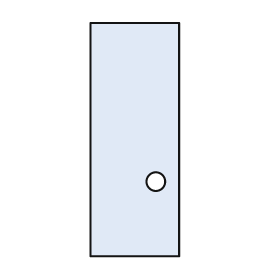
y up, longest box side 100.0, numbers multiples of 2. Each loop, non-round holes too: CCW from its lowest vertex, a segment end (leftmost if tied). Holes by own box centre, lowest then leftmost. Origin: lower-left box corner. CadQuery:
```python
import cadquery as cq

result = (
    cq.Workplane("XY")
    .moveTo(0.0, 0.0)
    .lineTo(38.0, 0.0)
    .lineTo(38.0, 100.0)
    .lineTo(0.0, 100.0)
    .close()
    .moveTo(28.0, 32.0)
    .circle(4.0)
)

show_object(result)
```